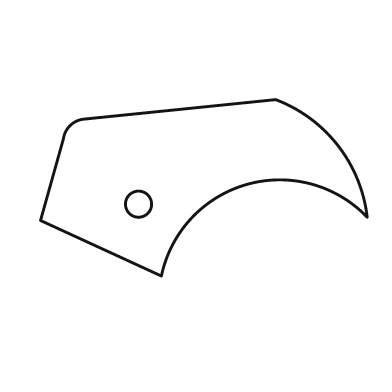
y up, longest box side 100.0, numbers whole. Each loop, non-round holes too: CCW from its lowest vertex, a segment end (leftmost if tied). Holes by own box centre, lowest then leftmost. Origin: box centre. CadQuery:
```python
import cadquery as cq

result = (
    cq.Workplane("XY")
    .moveTo(-13.0, -27.0)
    .threePointArc((13.0, 1.0), (50.0, -9.0))
    .threePointArc((41.0, 13.0), (22.0, 27.0))
    .lineTo(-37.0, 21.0)
    .threePointArc((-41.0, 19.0), (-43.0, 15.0))
    .lineTo(-50.0, -10.0)
    .close()
    .moveTo(-20.0, -5.0)
    .circle(4.0)
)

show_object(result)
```